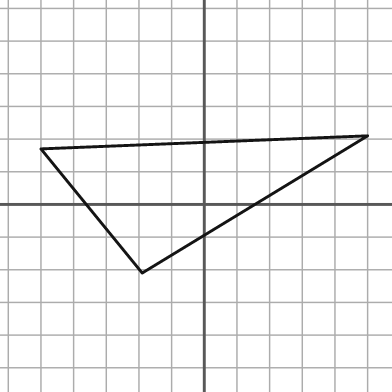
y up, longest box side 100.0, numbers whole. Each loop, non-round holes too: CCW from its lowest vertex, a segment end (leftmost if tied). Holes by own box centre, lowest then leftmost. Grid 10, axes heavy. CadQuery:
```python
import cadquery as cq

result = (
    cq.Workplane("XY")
    .moveTo(-19.0, -21.0)
    .lineTo(50.0, 21.0)
    .lineTo(-50.0, 17.0)
    .close()
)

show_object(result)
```